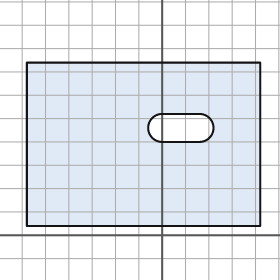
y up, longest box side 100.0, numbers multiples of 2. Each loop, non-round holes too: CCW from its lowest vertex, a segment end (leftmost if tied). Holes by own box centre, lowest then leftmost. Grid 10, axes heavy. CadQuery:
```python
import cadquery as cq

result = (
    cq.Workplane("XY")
    .moveTo(-58.0, 4.0)
    .lineTo(42.0, 4.0)
    .lineTo(42.0, 74.0)
    .lineTo(-58.0, 74.0)
    .close()
    .moveTo(0.0, 40.0)
    .lineTo(16.0, 40.0)
    .threePointArc((22.0, 46.0), (16.0, 52.0))
    .lineTo(0.0, 52.0)
    .threePointArc((-6.0, 46.0), (0.0, 40.0))
    .close()
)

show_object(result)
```